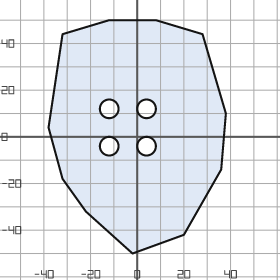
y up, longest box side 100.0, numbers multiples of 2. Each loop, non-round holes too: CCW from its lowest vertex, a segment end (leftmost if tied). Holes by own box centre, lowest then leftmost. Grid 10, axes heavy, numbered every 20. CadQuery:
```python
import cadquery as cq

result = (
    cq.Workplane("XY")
    .moveTo(-2.0, -50.0)
    .lineTo(20.0, -42.0)
    .lineTo(36.0, -14.0)
    .lineTo(38.0, 10.0)
    .lineTo(28.0, 44.0)
    .lineTo(8.0, 50.0)
    .lineTo(-12.0, 50.0)
    .lineTo(-32.0, 44.0)
    .lineTo(-38.0, 4.0)
    .lineTo(-32.0, -18.0)
    .lineTo(-22.0, -32.0)
    .close()
    .moveTo(-12.0, -4.0)
    .circle(4.0)
    .moveTo(4.0, -4.0)
    .circle(4.0)
    .moveTo(-12.0, 12.0)
    .circle(4.0)
    .moveTo(4.0, 12.0)
    .circle(4.0)
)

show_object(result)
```